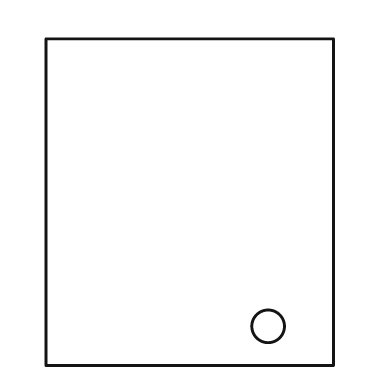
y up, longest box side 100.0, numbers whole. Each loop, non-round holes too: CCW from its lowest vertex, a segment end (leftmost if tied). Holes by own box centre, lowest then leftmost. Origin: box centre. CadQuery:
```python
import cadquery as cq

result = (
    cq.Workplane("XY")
    .moveTo(-44.0, -50.0)
    .lineTo(44.0, -50.0)
    .lineTo(44.0, 50.0)
    .lineTo(-44.0, 50.0)
    .close()
    .moveTo(24.0, -38.0)
    .circle(5.0)
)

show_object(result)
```